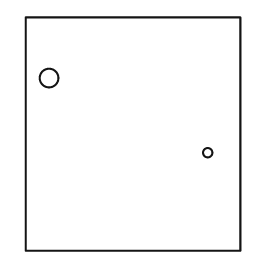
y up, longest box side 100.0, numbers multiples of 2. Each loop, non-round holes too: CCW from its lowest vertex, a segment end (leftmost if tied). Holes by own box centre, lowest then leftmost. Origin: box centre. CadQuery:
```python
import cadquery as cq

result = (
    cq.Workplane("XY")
    .moveTo(-46.0, -50.0)
    .lineTo(46.0, -50.0)
    .lineTo(46.0, 50.0)
    .lineTo(-46.0, 50.0)
    .close()
    .moveTo(32.0, -8.0)
    .circle(2.0)
    .moveTo(-36.0, 24.0)
    .circle(4.0)
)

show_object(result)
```